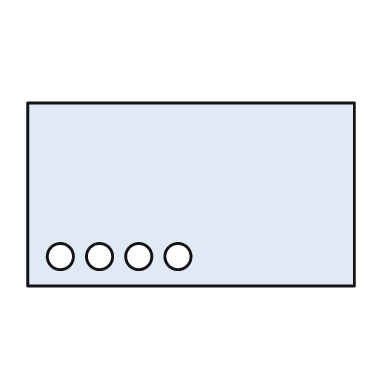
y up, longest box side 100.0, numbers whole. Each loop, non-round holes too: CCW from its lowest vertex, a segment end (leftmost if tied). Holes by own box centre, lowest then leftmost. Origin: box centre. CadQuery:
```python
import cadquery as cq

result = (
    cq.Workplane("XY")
    .moveTo(-50.0, -28.0)
    .lineTo(50.0, -28.0)
    .lineTo(50.0, 28.0)
    .lineTo(-50.0, 28.0)
    .close()
    .moveTo(-40.0, -19.0)
    .circle(4.0)
    .moveTo(-28.0, -19.0)
    .circle(4.0)
    .moveTo(-16.0, -19.0)
    .circle(4.0)
    .moveTo(-4.0, -19.0)
    .circle(4.0)
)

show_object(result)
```